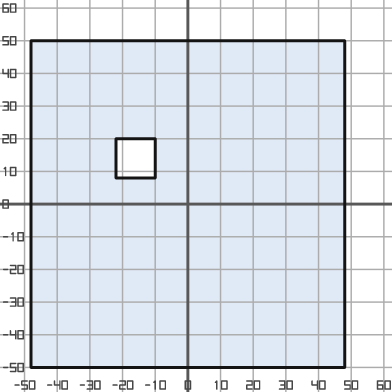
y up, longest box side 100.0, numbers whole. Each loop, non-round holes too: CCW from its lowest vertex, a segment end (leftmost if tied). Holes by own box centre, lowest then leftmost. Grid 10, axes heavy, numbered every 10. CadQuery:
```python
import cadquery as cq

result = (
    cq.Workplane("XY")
    .moveTo(-48.0, -50.0)
    .lineTo(48.0, -50.0)
    .lineTo(48.0, 50.0)
    .lineTo(-48.0, 50.0)
    .close()
    .moveTo(-22.0, 8.0)
    .lineTo(-10.0, 8.0)
    .lineTo(-10.0, 20.0)
    .lineTo(-22.0, 20.0)
    .close()
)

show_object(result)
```